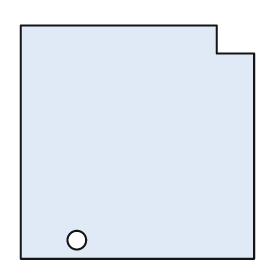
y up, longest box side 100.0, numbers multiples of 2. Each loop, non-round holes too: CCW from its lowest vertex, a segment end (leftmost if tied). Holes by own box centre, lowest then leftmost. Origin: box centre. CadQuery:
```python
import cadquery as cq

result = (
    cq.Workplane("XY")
    .moveTo(-50.0, -50.0)
    .lineTo(50.0, -50.0)
    .lineTo(50.0, 38.0)
    .lineTo(34.0, 38.0)
    .lineTo(34.0, 50.0)
    .lineTo(-50.0, 50.0)
    .close()
    .moveTo(-26.0, -42.0)
    .circle(4.0)
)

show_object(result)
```